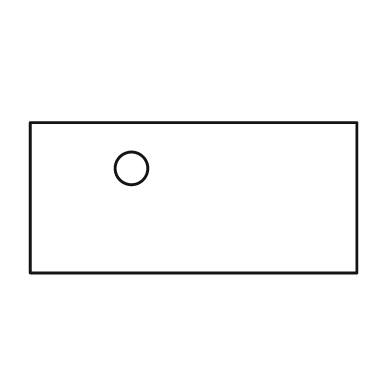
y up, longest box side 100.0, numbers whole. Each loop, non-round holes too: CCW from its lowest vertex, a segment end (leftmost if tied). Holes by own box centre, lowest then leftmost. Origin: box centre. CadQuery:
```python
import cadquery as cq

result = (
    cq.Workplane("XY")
    .moveTo(-50.0, -23.0)
    .lineTo(50.0, -23.0)
    .lineTo(50.0, 23.0)
    .lineTo(-50.0, 23.0)
    .close()
    .moveTo(-19.0, 9.0)
    .circle(5.0)
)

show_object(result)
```